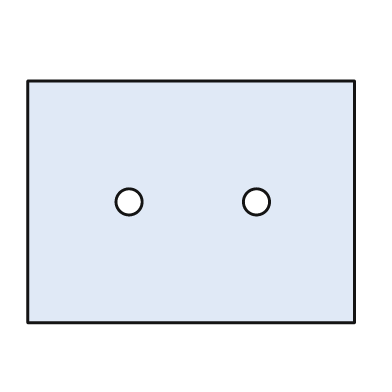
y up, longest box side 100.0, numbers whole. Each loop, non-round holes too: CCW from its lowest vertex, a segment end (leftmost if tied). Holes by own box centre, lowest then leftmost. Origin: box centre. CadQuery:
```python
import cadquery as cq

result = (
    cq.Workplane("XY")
    .moveTo(-50.0, -37.0)
    .lineTo(50.0, -37.0)
    .lineTo(50.0, 37.0)
    .lineTo(-50.0, 37.0)
    .close()
    .moveTo(-19.0, 0.0)
    .circle(4.0)
    .moveTo(20.0, 0.0)
    .circle(4.0)
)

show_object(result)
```